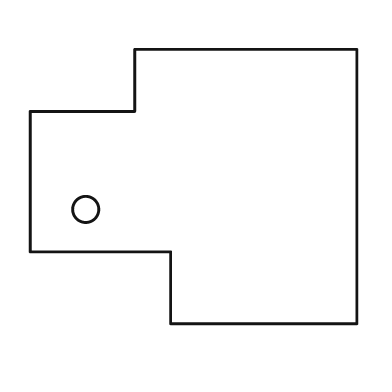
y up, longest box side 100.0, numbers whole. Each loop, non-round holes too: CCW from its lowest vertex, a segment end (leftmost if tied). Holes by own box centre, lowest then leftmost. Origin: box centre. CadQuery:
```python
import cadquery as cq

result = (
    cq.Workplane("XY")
    .moveTo(-7.0, -42.0)
    .lineTo(50.0, -42.0)
    .lineTo(50.0, 42.0)
    .lineTo(-18.0, 42.0)
    .lineTo(-18.0, 23.0)
    .lineTo(-50.0, 23.0)
    .lineTo(-50.0, -20.0)
    .lineTo(-7.0, -20.0)
    .close()
    .moveTo(-33.0, -7.0)
    .circle(4.0)
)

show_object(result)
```